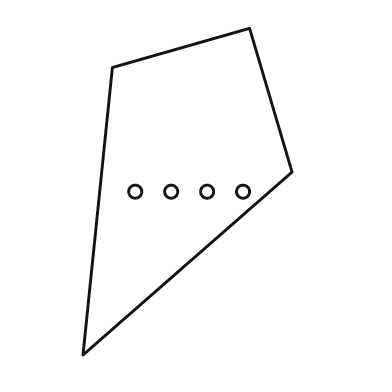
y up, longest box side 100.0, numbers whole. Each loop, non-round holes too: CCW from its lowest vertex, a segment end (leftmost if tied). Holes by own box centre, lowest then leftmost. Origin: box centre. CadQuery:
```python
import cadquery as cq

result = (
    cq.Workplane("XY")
    .moveTo(-32.0, -50.0)
    .lineTo(32.0, 6.0)
    .lineTo(19.0, 50.0)
    .lineTo(-23.0, 38.0)
    .close()
    .moveTo(-16.0, 0.0)
    .circle(2.0)
    .moveTo(-5.0, 0.0)
    .circle(2.0)
    .moveTo(6.0, 0.0)
    .circle(2.0)
    .moveTo(17.0, 0.0)
    .circle(2.0)
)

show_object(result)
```